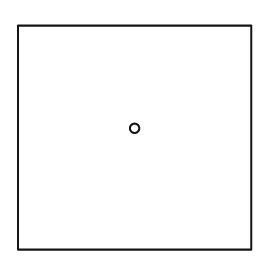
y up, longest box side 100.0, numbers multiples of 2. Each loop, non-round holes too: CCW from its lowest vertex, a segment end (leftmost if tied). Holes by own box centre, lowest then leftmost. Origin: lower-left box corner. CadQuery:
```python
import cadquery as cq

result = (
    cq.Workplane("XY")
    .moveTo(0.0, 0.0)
    .lineTo(100.0, 0.0)
    .lineTo(100.0, 96.0)
    .lineTo(0.0, 96.0)
    .close()
    .moveTo(50.0, 52.0)
    .circle(2.0)
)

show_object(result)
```